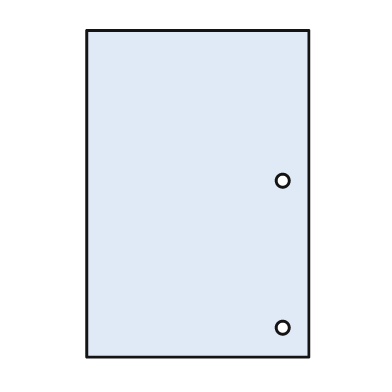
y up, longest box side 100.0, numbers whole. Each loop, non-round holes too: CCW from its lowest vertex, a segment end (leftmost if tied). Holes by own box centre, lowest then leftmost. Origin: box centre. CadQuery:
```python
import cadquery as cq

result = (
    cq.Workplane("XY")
    .moveTo(-34.0, -50.0)
    .lineTo(34.0, -50.0)
    .lineTo(34.0, 50.0)
    .lineTo(-34.0, 50.0)
    .close()
    .moveTo(26.0, -41.0)
    .circle(2.0)
    .moveTo(26.0, 4.0)
    .circle(2.0)
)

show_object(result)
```